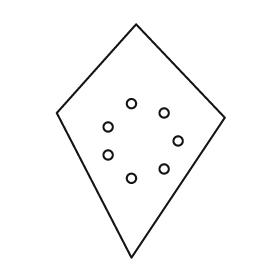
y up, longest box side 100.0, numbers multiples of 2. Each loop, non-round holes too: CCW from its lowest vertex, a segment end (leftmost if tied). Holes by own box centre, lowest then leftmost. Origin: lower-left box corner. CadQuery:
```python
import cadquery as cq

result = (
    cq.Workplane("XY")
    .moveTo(32.0, 0.0)
    .lineTo(72.0, 60.0)
    .lineTo(34.0, 100.0)
    .lineTo(0.0, 62.0)
    .close()
    .moveTo(32.0, 34.0)
    .circle(2.0)
    .moveTo(46.0, 38.0)
    .circle(2.0)
    .moveTo(22.0, 44.0)
    .circle(2.0)
    .moveTo(52.0, 50.0)
    .circle(2.0)
    .moveTo(22.0, 56.0)
    .circle(2.0)
    .moveTo(46.0, 62.0)
    .circle(2.0)
    .moveTo(32.0, 66.0)
    .circle(2.0)
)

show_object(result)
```